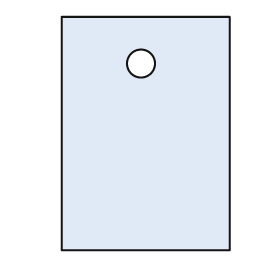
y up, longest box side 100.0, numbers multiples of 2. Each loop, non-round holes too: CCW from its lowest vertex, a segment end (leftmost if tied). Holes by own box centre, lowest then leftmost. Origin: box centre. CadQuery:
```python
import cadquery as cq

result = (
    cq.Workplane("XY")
    .moveTo(-36.0, -50.0)
    .lineTo(36.0, -50.0)
    .lineTo(36.0, 50.0)
    .lineTo(-36.0, 50.0)
    .close()
    .moveTo(-2.0, 30.0)
    .circle(6.0)
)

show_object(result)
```